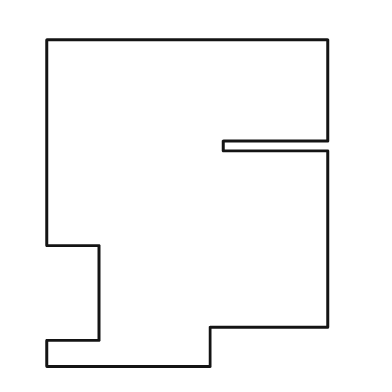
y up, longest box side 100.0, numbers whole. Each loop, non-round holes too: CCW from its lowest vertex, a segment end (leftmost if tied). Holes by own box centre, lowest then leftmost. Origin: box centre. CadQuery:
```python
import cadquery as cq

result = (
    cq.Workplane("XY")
    .moveTo(-43.0, -50.0)
    .lineTo(7.0, -50.0)
    .lineTo(7.0, -38.0)
    .lineTo(43.0, -38.0)
    .lineTo(43.0, 16.0)
    .lineTo(11.0, 16.0)
    .lineTo(11.0, 19.0)
    .lineTo(43.0, 19.0)
    .lineTo(43.0, 50.0)
    .lineTo(-43.0, 50.0)
    .lineTo(-43.0, -13.0)
    .lineTo(-27.0, -13.0)
    .lineTo(-27.0, -42.0)
    .lineTo(-43.0, -42.0)
    .close()
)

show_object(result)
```